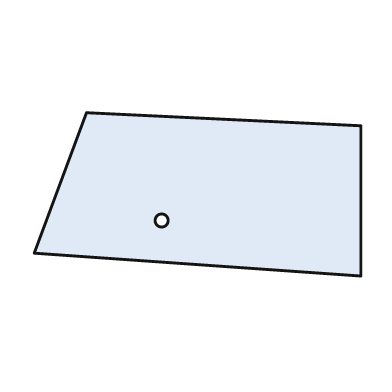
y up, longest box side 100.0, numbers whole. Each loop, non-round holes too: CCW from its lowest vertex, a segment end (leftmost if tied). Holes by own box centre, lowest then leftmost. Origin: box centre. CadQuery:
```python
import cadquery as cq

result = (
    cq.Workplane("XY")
    .moveTo(50.0, -25.0)
    .lineTo(50.0, 21.0)
    .lineTo(-34.0, 25.0)
    .lineTo(-50.0, -18.0)
    .close()
    .moveTo(-11.0, -8.0)
    .circle(2.0)
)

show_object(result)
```